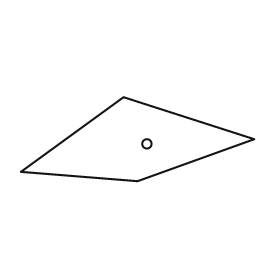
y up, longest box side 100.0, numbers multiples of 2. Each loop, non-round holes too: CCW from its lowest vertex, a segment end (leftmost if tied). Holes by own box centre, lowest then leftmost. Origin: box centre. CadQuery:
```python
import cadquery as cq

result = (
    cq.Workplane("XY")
    .moveTo(0.0, -18.0)
    .lineTo(50.0, 0.0)
    .lineTo(-6.0, 18.0)
    .lineTo(-50.0, -14.0)
    .close()
    .moveTo(4.0, -2.0)
    .circle(2.0)
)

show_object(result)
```